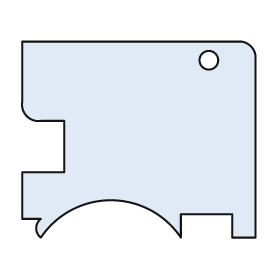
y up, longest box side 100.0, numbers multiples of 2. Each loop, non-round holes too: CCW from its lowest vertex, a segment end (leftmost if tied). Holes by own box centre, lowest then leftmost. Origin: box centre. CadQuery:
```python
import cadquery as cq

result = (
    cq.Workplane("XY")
    .moveTo(-42.0, -42.0)
    .threePointArc((-12.0, -26.0), (18.0, -42.0))
    .lineTo(18.0, -32.0)
    .lineTo(40.0, -32.0)
    .lineTo(40.0, -42.0)
    .lineTo(50.0, -42.0)
    .lineTo(50.0, 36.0)
    .threePointArc((48.0, 40.0), (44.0, 42.0))
    .lineTo(-50.0, 42.0)
    .lineTo(-50.0, 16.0)
    .threePointArc((-48.0, 10.0), (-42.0, 8.0))
    .lineTo(-32.0, 8.0)
    .lineTo(-32.0, -14.0)
    .lineTo(-50.0, -14.0)
    .lineTo(-50.0, -34.0)
    .lineTo(-42.0, -34.0)
    .threePointArc((-44.0, -38.0), (-42.0, -42.0))
    .close()
    .moveTo(30.0, 34.0)
    .circle(4.0)
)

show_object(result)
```